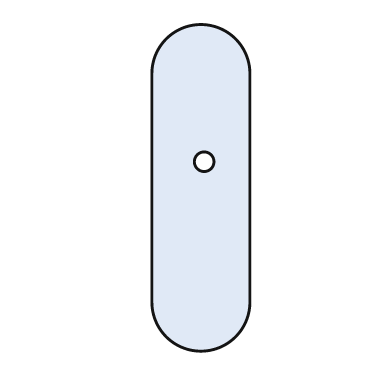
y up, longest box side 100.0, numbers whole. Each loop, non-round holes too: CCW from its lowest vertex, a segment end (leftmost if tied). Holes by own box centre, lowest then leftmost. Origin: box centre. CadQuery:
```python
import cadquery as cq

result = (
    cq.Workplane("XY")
    .moveTo(-15.0, -35.0)
    .threePointArc((0.0, -50.0), (15.0, -35.0))
    .lineTo(15.0, 35.0)
    .threePointArc((0.0, 50.0), (-15.0, 35.0))
    .close()
    .moveTo(1.0, 8.0)
    .circle(3.0)
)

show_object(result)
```